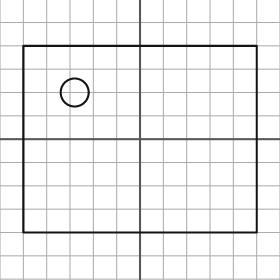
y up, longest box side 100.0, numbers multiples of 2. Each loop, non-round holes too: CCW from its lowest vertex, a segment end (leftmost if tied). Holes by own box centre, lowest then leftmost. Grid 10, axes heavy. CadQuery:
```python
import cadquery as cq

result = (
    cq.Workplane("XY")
    .moveTo(-50.0, -40.0)
    .lineTo(50.0, -40.0)
    .lineTo(50.0, 40.0)
    .lineTo(-50.0, 40.0)
    .close()
    .moveTo(-28.0, 20.0)
    .circle(6.0)
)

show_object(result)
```